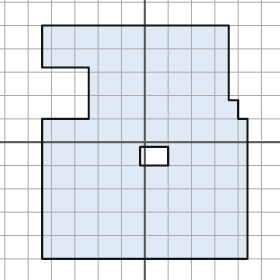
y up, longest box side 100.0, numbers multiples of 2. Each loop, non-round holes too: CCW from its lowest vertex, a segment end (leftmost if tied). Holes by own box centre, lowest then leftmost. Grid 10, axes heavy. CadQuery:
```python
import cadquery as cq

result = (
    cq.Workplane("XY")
    .moveTo(-44.0, -50.0)
    .lineTo(44.0, -50.0)
    .lineTo(44.0, 10.0)
    .lineTo(40.0, 10.0)
    .lineTo(40.0, 18.0)
    .lineTo(36.0, 18.0)
    .lineTo(36.0, 50.0)
    .lineTo(-44.0, 50.0)
    .lineTo(-44.0, 32.0)
    .lineTo(-24.0, 32.0)
    .lineTo(-24.0, 10.0)
    .lineTo(-44.0, 10.0)
    .close()
    .moveTo(-2.0, -10.0)
    .lineTo(10.0, -10.0)
    .lineTo(10.0, -2.0)
    .lineTo(-2.0, -2.0)
    .close()
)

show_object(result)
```